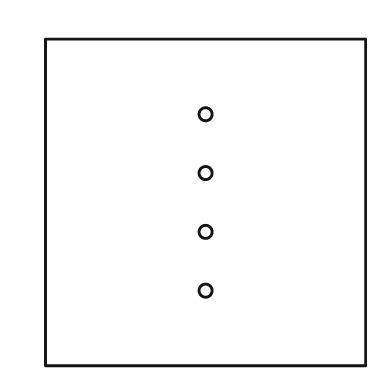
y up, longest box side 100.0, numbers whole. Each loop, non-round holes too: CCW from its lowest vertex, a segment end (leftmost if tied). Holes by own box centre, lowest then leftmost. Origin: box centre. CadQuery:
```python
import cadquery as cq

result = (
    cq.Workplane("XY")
    .moveTo(-49.0, -50.0)
    .lineTo(49.0, -50.0)
    .lineTo(49.0, 50.0)
    .lineTo(-49.0, 50.0)
    .close()
    .moveTo(0.0, -27.0)
    .circle(2.0)
    .moveTo(0.0, -9.0)
    .circle(2.0)
    .moveTo(0.0, 9.0)
    .circle(2.0)
    .moveTo(0.0, 27.0)
    .circle(2.0)
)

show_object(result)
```